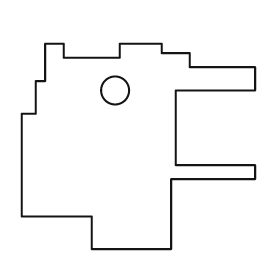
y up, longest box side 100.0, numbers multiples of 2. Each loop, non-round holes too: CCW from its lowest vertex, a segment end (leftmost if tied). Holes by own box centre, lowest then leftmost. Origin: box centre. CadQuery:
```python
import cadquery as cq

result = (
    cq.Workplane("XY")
    .moveTo(-20.0, -44.0)
    .lineTo(14.0, -44.0)
    .lineTo(14.0, -14.0)
    .lineTo(50.0, -14.0)
    .lineTo(50.0, -8.0)
    .lineTo(16.0, -8.0)
    .lineTo(16.0, 24.0)
    .lineTo(50.0, 24.0)
    .lineTo(50.0, 34.0)
    .lineTo(22.0, 34.0)
    .lineTo(22.0, 40.0)
    .lineTo(10.0, 40.0)
    .lineTo(10.0, 44.0)
    .lineTo(-8.0, 44.0)
    .lineTo(-8.0, 38.0)
    .lineTo(-32.0, 38.0)
    .lineTo(-32.0, 44.0)
    .lineTo(-40.0, 44.0)
    .lineTo(-40.0, 28.0)
    .lineTo(-44.0, 28.0)
    .lineTo(-44.0, 14.0)
    .lineTo(-50.0, 14.0)
    .lineTo(-50.0, -30.0)
    .lineTo(-20.0, -30.0)
    .close()
    .moveTo(-10.0, 24.0)
    .circle(6.0)
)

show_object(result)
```